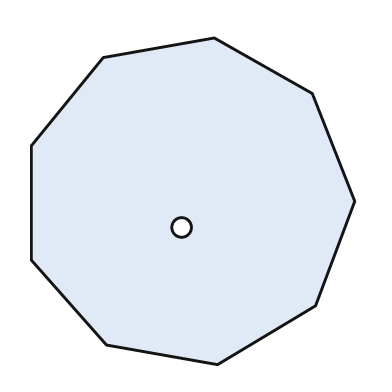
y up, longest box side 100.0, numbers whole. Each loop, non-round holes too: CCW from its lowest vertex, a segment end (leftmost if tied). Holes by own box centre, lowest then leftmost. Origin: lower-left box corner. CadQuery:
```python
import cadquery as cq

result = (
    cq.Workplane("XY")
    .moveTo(57.0, 0.0)
    .lineTo(87.0, 18.0)
    .lineTo(99.0, 50.0)
    .lineTo(86.0, 83.0)
    .lineTo(56.0, 100.0)
    .lineTo(22.0, 94.0)
    .lineTo(0.0, 67.0)
    .lineTo(0.0, 32.0)
    .lineTo(23.0, 6.0)
    .close()
    .moveTo(46.0, 42.0)
    .circle(3.0)
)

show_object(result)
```